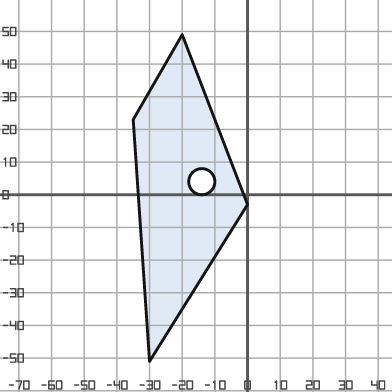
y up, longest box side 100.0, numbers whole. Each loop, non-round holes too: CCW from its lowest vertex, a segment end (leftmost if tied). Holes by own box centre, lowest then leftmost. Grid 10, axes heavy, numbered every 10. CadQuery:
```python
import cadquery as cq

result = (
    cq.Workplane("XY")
    .moveTo(-30.0, -51.0)
    .lineTo(0.0, -3.0)
    .lineTo(-20.0, 49.0)
    .lineTo(-35.0, 23.0)
    .close()
    .moveTo(-14.0, 4.0)
    .circle(4.0)
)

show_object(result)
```